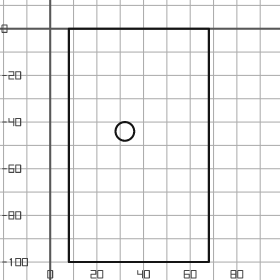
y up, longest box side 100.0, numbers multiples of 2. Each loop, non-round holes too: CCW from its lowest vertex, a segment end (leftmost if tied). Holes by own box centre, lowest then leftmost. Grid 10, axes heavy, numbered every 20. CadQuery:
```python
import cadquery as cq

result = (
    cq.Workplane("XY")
    .moveTo(8.0, -100.0)
    .lineTo(68.0, -100.0)
    .lineTo(68.0, 0.0)
    .lineTo(8.0, 0.0)
    .close()
    .moveTo(32.0, -44.0)
    .circle(4.0)
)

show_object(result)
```